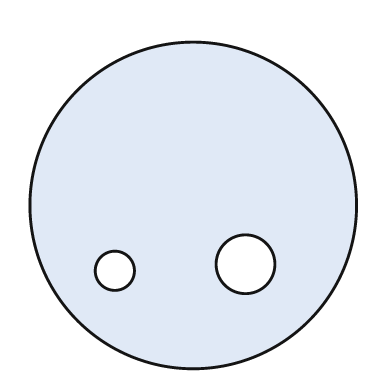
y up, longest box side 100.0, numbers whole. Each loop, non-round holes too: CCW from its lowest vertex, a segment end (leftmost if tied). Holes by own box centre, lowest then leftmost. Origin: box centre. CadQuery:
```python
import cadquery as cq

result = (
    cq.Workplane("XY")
    .moveTo(0.0, 0.0)
    .circle(50.0)
    .moveTo(-24.0, -20.0)
    .circle(6.0)
    .moveTo(16.0, -18.0)
    .circle(9.0)
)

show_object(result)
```